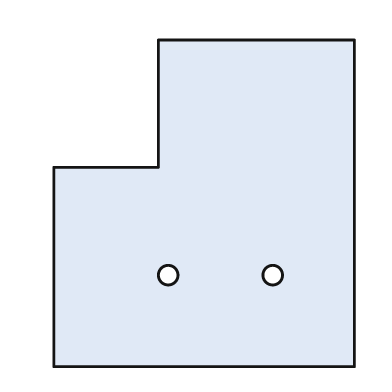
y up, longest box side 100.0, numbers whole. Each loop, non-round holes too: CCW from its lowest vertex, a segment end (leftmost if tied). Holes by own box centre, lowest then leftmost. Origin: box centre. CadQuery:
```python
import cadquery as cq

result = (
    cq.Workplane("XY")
    .moveTo(-46.0, -50.0)
    .lineTo(46.0, -50.0)
    .lineTo(46.0, 50.0)
    .lineTo(-14.0, 50.0)
    .lineTo(-14.0, 11.0)
    .lineTo(-46.0, 11.0)
    .close()
    .moveTo(-11.0, -22.0)
    .circle(3.0)
    .moveTo(21.0, -22.0)
    .circle(3.0)
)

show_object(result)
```